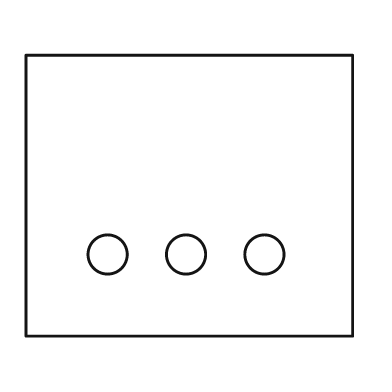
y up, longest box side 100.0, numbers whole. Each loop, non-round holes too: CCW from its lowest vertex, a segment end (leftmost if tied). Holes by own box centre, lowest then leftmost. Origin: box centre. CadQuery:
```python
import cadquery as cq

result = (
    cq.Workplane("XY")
    .moveTo(-50.0, -43.0)
    .lineTo(50.0, -43.0)
    .lineTo(50.0, 43.0)
    .lineTo(-50.0, 43.0)
    .close()
    .moveTo(-25.0, -18.0)
    .circle(6.0)
    .moveTo(-1.0, -18.0)
    .circle(6.0)
    .moveTo(23.0, -18.0)
    .circle(6.0)
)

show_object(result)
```